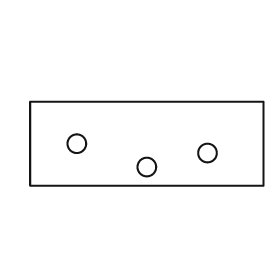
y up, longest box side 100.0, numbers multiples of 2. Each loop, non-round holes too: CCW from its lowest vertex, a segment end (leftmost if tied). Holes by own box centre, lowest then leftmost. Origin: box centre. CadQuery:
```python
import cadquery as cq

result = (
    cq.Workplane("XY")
    .moveTo(-50.0, -18.0)
    .lineTo(50.0, -18.0)
    .lineTo(50.0, 18.0)
    .lineTo(-50.0, 18.0)
    .close()
    .moveTo(0.0, -10.0)
    .circle(4.0)
    .moveTo(26.0, -4.0)
    .circle(4.0)
    .moveTo(-30.0, 0.0)
    .circle(4.0)
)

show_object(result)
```